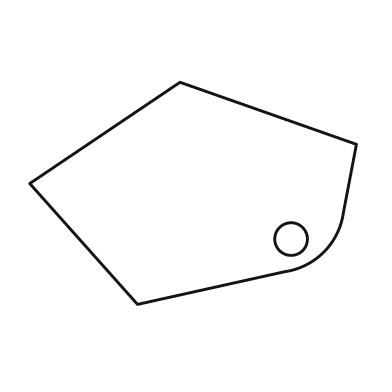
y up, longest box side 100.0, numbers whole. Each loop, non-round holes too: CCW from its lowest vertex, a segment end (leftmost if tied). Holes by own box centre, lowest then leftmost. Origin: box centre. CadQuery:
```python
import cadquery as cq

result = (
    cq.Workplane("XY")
    .moveTo(-17.0, -34.0)
    .lineTo(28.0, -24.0)
    .threePointArc((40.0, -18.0), (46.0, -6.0))
    .lineTo(50.0, 15.0)
    .lineTo(-4.0, 34.0)
    .lineTo(-50.0, 3.0)
    .close()
    .moveTo(30.0, -14.0)
    .circle(5.0)
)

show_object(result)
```